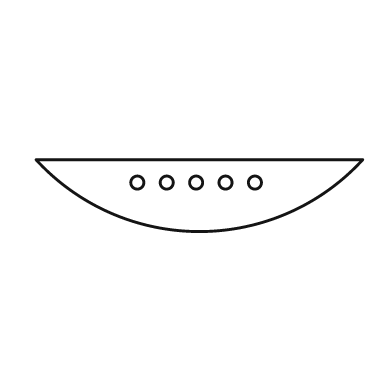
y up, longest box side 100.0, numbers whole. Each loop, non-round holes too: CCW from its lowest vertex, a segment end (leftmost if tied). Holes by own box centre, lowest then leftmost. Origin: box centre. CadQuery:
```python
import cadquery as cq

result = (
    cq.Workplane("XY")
    .moveTo(-50.0, 11.0)
    .threePointArc((0.0, -11.0), (50.0, 11.0))
    .close()
    .moveTo(-19.0, 4.0)
    .circle(2.0)
    .moveTo(-10.0, 4.0)
    .circle(2.0)
    .moveTo(-1.0, 4.0)
    .circle(2.0)
    .moveTo(8.0, 4.0)
    .circle(2.0)
    .moveTo(17.0, 4.0)
    .circle(2.0)
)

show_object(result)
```